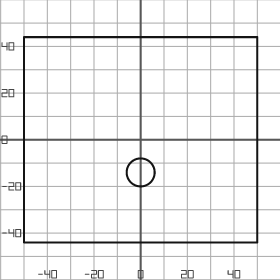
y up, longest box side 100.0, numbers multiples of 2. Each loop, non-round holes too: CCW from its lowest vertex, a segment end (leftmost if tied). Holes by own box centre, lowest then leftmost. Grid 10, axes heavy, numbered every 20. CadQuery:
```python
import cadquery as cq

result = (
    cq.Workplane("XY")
    .moveTo(-50.0, -44.0)
    .lineTo(50.0, -44.0)
    .lineTo(50.0, 44.0)
    .lineTo(-50.0, 44.0)
    .close()
    .moveTo(0.0, -14.0)
    .circle(6.0)
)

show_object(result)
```